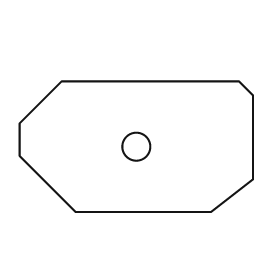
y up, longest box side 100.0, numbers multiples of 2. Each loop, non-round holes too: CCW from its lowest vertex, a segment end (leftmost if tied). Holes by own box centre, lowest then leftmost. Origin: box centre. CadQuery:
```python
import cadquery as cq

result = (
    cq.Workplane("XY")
    .moveTo(-26.0, -28.0)
    .lineTo(32.0, -28.0)
    .lineTo(50.0, -14.0)
    .lineTo(50.0, 22.0)
    .lineTo(44.0, 28.0)
    .lineTo(-32.0, 28.0)
    .lineTo(-50.0, 10.0)
    .lineTo(-50.0, -4.0)
    .close()
    .moveTo(0.0, 0.0)
    .circle(6.0)
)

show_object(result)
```